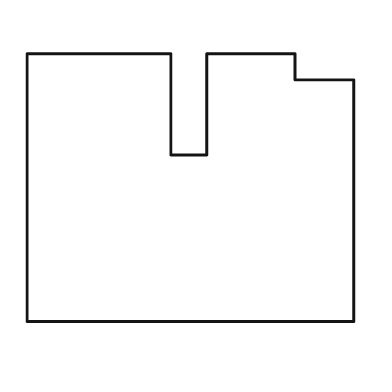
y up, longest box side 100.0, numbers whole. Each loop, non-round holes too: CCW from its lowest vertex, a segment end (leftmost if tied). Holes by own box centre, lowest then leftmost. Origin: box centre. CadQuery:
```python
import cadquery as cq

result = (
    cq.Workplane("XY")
    .moveTo(-50.0, -41.0)
    .lineTo(50.0, -41.0)
    .lineTo(50.0, 33.0)
    .lineTo(32.0, 33.0)
    .lineTo(32.0, 41.0)
    .lineTo(5.0, 41.0)
    .lineTo(5.0, 10.0)
    .lineTo(-6.0, 10.0)
    .lineTo(-6.0, 41.0)
    .lineTo(-50.0, 41.0)
    .close()
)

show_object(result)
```